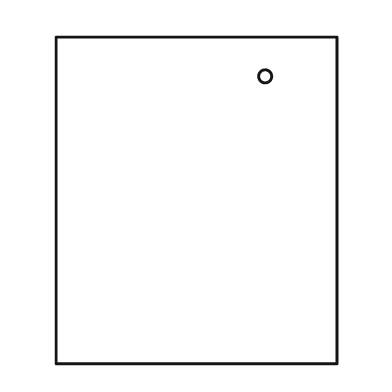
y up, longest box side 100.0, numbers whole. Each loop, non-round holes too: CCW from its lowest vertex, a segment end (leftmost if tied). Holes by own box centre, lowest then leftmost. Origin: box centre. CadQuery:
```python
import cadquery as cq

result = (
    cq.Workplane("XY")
    .moveTo(-43.0, -50.0)
    .lineTo(43.0, -50.0)
    .lineTo(43.0, 50.0)
    .lineTo(-43.0, 50.0)
    .close()
    .moveTo(21.0, 38.0)
    .circle(2.0)
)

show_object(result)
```